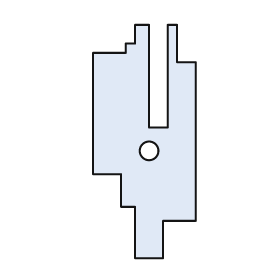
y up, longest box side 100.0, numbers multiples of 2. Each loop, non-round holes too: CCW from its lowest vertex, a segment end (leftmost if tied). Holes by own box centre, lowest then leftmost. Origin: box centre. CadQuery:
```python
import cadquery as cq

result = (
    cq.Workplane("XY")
    .moveTo(-4.0, -50.0)
    .lineTo(8.0, -50.0)
    .lineTo(8.0, -34.0)
    .lineTo(22.0, -34.0)
    .lineTo(22.0, 34.0)
    .lineTo(14.0, 34.0)
    .lineTo(14.0, 50.0)
    .lineTo(10.0, 50.0)
    .lineTo(10.0, 6.0)
    .lineTo(2.0, 6.0)
    .lineTo(2.0, 50.0)
    .lineTo(-4.0, 50.0)
    .lineTo(-4.0, 42.0)
    .lineTo(-8.0, 42.0)
    .lineTo(-8.0, 38.0)
    .lineTo(-22.0, 38.0)
    .lineTo(-22.0, -14.0)
    .lineTo(-10.0, -14.0)
    .lineTo(-10.0, -28.0)
    .lineTo(-4.0, -28.0)
    .close()
    .moveTo(2.0, -4.0)
    .circle(4.0)
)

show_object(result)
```